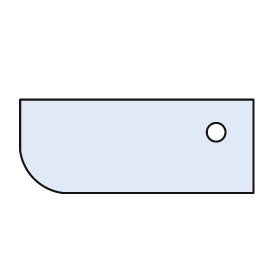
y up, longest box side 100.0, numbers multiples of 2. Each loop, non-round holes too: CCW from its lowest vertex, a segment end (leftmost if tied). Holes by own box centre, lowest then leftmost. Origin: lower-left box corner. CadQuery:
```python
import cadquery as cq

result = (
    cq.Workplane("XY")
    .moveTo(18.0, 0.0)
    .lineTo(100.0, 0.0)
    .lineTo(100.0, 40.0)
    .lineTo(0.0, 40.0)
    .lineTo(0.0, 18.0)
    .threePointArc((6.0, 6.0), (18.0, 0.0))
    .close()
    .moveTo(84.0, 26.0)
    .circle(4.0)
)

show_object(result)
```